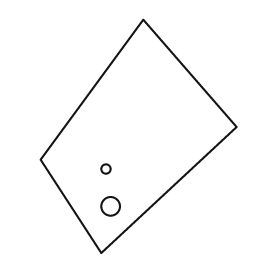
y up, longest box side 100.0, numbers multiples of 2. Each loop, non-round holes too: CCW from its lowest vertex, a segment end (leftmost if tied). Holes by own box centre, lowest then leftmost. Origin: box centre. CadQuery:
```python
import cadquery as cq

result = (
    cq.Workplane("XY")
    .moveTo(-16.0, -50.0)
    .lineTo(42.0, 4.0)
    .lineTo(2.0, 50.0)
    .lineTo(-42.0, -10.0)
    .close()
    .moveTo(-12.0, -30.0)
    .circle(4.0)
    .moveTo(-14.0, -14.0)
    .circle(2.0)
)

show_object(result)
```